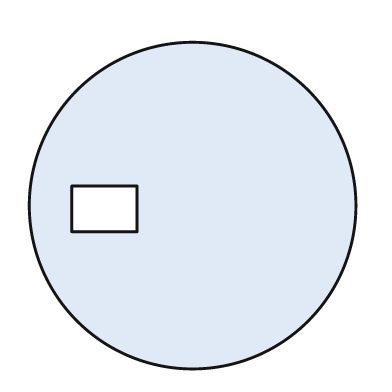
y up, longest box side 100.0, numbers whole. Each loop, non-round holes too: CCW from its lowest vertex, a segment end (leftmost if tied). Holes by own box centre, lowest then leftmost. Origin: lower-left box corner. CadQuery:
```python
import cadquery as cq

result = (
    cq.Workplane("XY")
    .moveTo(50.0, 50.0)
    .circle(50.0)
    .moveTo(13.0, 42.0)
    .lineTo(33.0, 42.0)
    .lineTo(33.0, 56.0)
    .lineTo(13.0, 56.0)
    .close()
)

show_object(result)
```